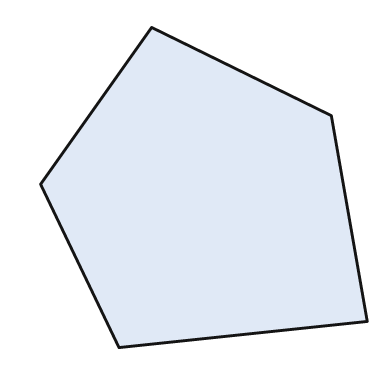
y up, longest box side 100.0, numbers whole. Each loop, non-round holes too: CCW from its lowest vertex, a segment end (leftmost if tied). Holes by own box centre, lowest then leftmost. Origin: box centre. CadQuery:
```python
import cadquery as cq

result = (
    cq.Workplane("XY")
    .moveTo(-26.0, -49.0)
    .lineTo(50.0, -41.0)
    .lineTo(39.0, 22.0)
    .lineTo(-16.0, 49.0)
    .lineTo(-50.0, 1.0)
    .close()
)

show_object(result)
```